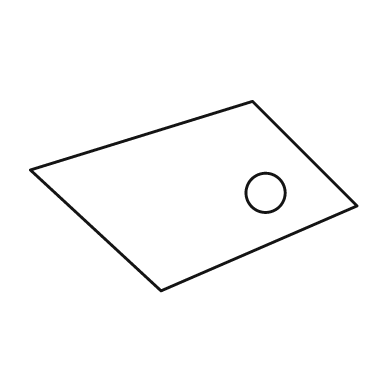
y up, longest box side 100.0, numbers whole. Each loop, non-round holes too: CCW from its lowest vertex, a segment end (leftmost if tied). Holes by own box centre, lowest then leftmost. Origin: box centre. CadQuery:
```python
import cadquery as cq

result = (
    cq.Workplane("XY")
    .moveTo(-10.0, -29.0)
    .lineTo(50.0, -3.0)
    .lineTo(18.0, 29.0)
    .lineTo(-50.0, 8.0)
    .close()
    .moveTo(22.0, 1.0)
    .circle(6.0)
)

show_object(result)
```